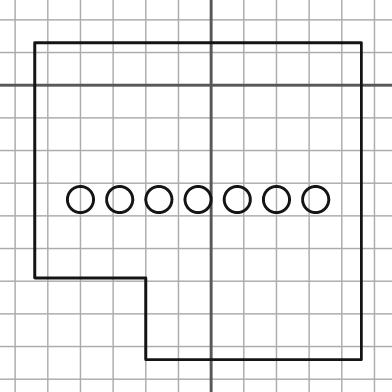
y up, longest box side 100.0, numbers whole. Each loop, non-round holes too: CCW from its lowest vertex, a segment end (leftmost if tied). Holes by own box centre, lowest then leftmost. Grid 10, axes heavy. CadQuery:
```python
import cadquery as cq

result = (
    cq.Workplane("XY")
    .moveTo(-20.0, -84.0)
    .lineTo(46.0, -84.0)
    .lineTo(46.0, 13.0)
    .lineTo(-54.0, 13.0)
    .lineTo(-54.0, -59.0)
    .lineTo(-20.0, -59.0)
    .close()
    .moveTo(-40.0, -35.0)
    .circle(4.0)
    .moveTo(-28.0, -35.0)
    .circle(4.0)
    .moveTo(-16.0, -35.0)
    .circle(4.0)
    .moveTo(-4.0, -35.0)
    .circle(4.0)
    .moveTo(8.0, -35.0)
    .circle(4.0)
    .moveTo(20.0, -35.0)
    .circle(4.0)
    .moveTo(32.0, -35.0)
    .circle(4.0)
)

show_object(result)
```